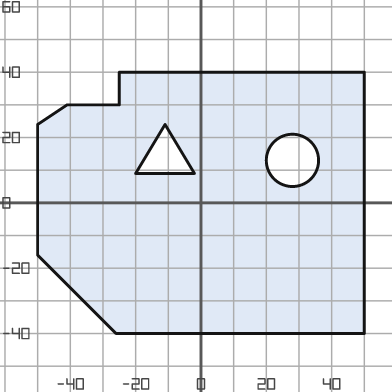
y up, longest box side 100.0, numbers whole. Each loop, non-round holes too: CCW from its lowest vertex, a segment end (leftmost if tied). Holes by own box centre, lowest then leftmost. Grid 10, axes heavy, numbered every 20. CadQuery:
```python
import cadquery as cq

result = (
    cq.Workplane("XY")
    .moveTo(-26.0, -40.0)
    .lineTo(50.0, -40.0)
    .lineTo(50.0, 40.0)
    .lineTo(-25.0, 40.0)
    .lineTo(-25.0, 30.0)
    .lineTo(-41.0, 30.0)
    .lineTo(-50.0, 24.0)
    .lineTo(-50.0, -16.0)
    .close()
    .moveTo(28.0, 13.0)
    .circle(8.0)
    .moveTo(-20.0, 9.0)
    .lineTo(-2.0, 9.0)
    .lineTo(-11.0, 24.0)
    .close()
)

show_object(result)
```